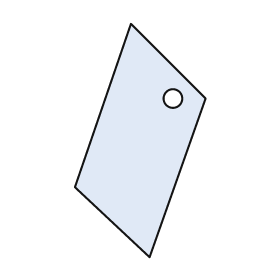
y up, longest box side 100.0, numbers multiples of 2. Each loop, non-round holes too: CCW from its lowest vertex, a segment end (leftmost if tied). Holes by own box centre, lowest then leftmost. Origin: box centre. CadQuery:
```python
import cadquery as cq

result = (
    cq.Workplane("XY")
    .moveTo(4.0, -50.0)
    .lineTo(28.0, 18.0)
    .lineTo(-4.0, 50.0)
    .lineTo(-28.0, -20.0)
    .close()
    .moveTo(14.0, 18.0)
    .circle(4.0)
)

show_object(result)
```